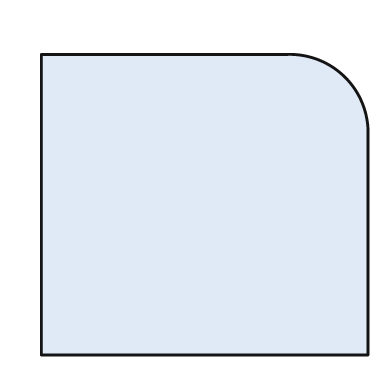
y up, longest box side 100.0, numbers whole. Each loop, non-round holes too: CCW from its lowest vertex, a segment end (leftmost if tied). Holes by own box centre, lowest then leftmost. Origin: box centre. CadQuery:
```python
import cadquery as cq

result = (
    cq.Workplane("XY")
    .moveTo(-50.0, -46.0)
    .lineTo(50.0, -46.0)
    .lineTo(50.0, 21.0)
    .threePointArc((43.0, 39.0), (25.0, 46.0))
    .lineTo(-50.0, 46.0)
    .close()
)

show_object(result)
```